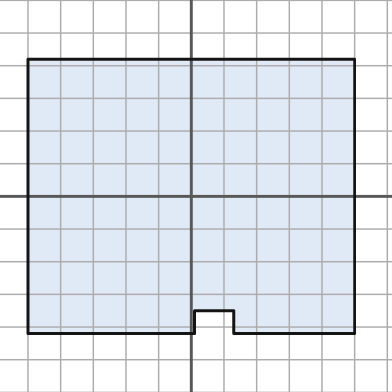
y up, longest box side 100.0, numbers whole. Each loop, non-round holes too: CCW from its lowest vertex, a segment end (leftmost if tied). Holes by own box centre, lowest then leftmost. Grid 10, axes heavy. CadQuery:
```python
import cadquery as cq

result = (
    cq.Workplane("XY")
    .moveTo(-50.0, -42.0)
    .lineTo(1.0, -42.0)
    .lineTo(1.0, -35.0)
    .lineTo(13.0, -35.0)
    .lineTo(13.0, -42.0)
    .lineTo(50.0, -42.0)
    .lineTo(50.0, 42.0)
    .lineTo(-50.0, 42.0)
    .close()
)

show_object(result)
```